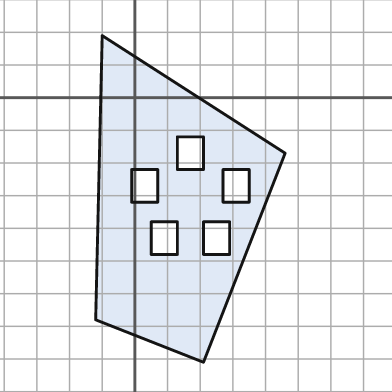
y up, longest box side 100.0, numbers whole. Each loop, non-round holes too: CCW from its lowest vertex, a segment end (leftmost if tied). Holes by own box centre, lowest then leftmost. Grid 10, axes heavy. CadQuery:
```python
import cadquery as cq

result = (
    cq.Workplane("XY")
    .moveTo(21.0, -81.0)
    .lineTo(46.0, -17.0)
    .lineTo(-10.0, 19.0)
    .lineTo(-12.0, -68.0)
    .close()
    .moveTo(5.0, -48.0)
    .lineTo(13.0, -48.0)
    .lineTo(13.0, -38.0)
    .lineTo(5.0, -38.0)
    .close()
    .moveTo(21.0, -48.0)
    .lineTo(29.0, -48.0)
    .lineTo(29.0, -38.0)
    .lineTo(21.0, -38.0)
    .close()
    .moveTo(-1.0, -32.0)
    .lineTo(7.0, -32.0)
    .lineTo(7.0, -22.0)
    .lineTo(-1.0, -22.0)
    .close()
    .moveTo(27.0, -32.0)
    .lineTo(35.0, -32.0)
    .lineTo(35.0, -22.0)
    .lineTo(27.0, -22.0)
    .close()
    .moveTo(13.0, -22.0)
    .lineTo(21.0, -22.0)
    .lineTo(21.0, -12.0)
    .lineTo(13.0, -12.0)
    .close()
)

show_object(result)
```